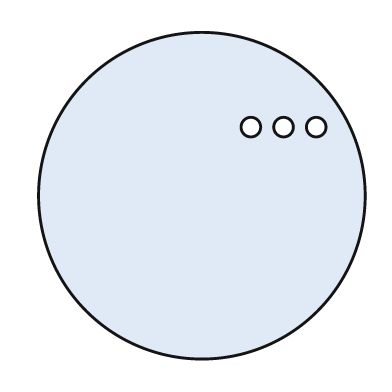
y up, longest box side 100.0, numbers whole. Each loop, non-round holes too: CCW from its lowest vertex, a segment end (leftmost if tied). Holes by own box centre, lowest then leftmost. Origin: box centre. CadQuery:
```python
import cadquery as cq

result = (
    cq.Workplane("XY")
    .moveTo(0.0, 0.0)
    .circle(50.0)
    .moveTo(15.0, 21.0)
    .circle(3.0)
    .moveTo(25.0, 21.0)
    .circle(3.0)
    .moveTo(35.0, 21.0)
    .circle(3.0)
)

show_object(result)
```